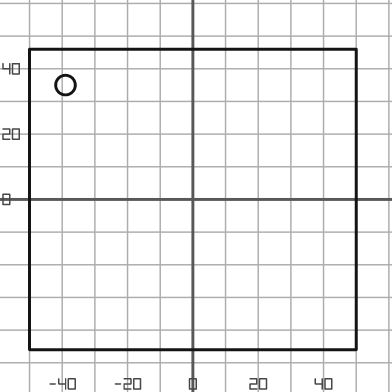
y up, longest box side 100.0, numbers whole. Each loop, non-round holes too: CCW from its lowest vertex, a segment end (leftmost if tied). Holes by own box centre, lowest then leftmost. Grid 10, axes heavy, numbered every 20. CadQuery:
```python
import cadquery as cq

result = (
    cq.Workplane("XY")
    .moveTo(-50.0, -46.0)
    .lineTo(50.0, -46.0)
    .lineTo(50.0, 46.0)
    .lineTo(-50.0, 46.0)
    .close()
    .moveTo(-39.0, 35.0)
    .circle(3.0)
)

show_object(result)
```